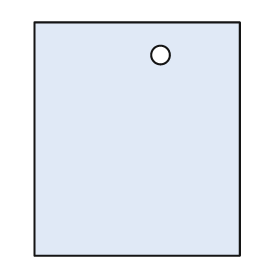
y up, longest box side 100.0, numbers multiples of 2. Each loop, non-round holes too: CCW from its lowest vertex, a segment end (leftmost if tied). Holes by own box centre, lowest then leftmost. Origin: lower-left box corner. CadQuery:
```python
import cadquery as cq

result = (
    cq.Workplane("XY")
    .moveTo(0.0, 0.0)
    .lineTo(88.0, 0.0)
    .lineTo(88.0, 100.0)
    .lineTo(0.0, 100.0)
    .close()
    .moveTo(54.0, 86.0)
    .circle(4.0)
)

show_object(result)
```